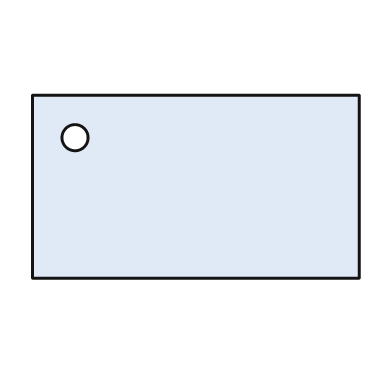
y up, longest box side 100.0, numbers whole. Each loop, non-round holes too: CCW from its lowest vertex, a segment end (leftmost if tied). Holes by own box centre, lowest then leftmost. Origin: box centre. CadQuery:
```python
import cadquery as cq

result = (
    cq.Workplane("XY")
    .moveTo(-50.0, -28.0)
    .lineTo(50.0, -28.0)
    .lineTo(50.0, 28.0)
    .lineTo(-50.0, 28.0)
    .close()
    .moveTo(-37.0, 15.0)
    .circle(4.0)
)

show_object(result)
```